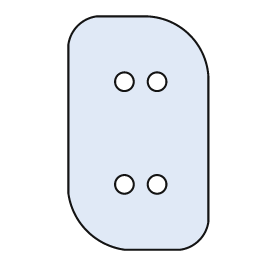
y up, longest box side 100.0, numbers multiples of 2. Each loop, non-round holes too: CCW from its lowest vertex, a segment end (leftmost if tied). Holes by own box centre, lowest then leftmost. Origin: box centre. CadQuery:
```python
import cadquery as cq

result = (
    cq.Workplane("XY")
    .moveTo(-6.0, -50.0)
    .lineTo(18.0, -50.0)
    .threePointArc((26.0, -46.0), (30.0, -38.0))
    .lineTo(30.0, 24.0)
    .threePointArc((22.0, 42.0), (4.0, 50.0))
    .lineTo(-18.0, 50.0)
    .threePointArc((-26.0, 46.0), (-30.0, 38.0))
    .lineTo(-30.0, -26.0)
    .threePointArc((-22.0, -42.0), (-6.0, -50.0))
    .close()
    .moveTo(-6.0, -22.0)
    .circle(4.0)
    .moveTo(8.0, -22.0)
    .circle(4.0)
    .moveTo(-6.0, 22.0)
    .circle(4.0)
    .moveTo(8.0, 22.0)
    .circle(4.0)
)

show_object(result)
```